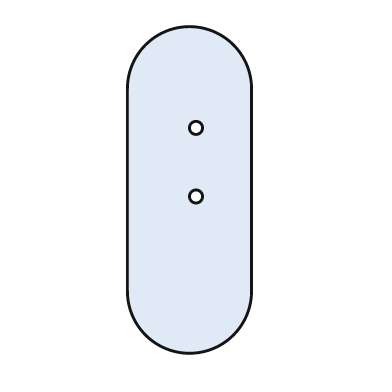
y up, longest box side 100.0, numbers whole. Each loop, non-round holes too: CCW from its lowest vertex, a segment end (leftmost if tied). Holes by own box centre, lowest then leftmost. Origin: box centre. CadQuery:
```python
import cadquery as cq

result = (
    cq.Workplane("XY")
    .moveTo(-19.0, -31.0)
    .threePointArc((0.0, -50.0), (19.0, -31.0))
    .lineTo(19.0, 31.0)
    .threePointArc((0.0, 50.0), (-19.0, 31.0))
    .close()
    .moveTo(2.0, -2.0)
    .circle(2.0)
    .moveTo(2.0, 19.0)
    .circle(2.0)
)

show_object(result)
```